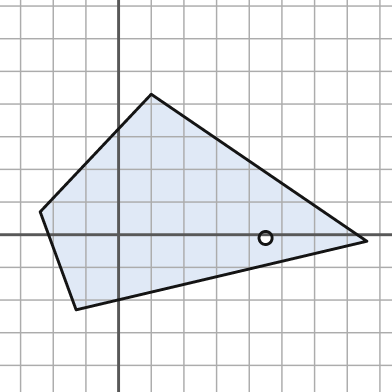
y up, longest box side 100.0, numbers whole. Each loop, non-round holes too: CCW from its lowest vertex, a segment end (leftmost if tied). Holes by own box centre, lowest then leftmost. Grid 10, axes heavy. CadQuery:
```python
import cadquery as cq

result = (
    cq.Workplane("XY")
    .moveTo(-13.0, -23.0)
    .lineTo(76.0, -2.0)
    .lineTo(10.0, 43.0)
    .lineTo(-24.0, 7.0)
    .close()
    .moveTo(45.0, -1.0)
    .circle(2.0)
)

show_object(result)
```